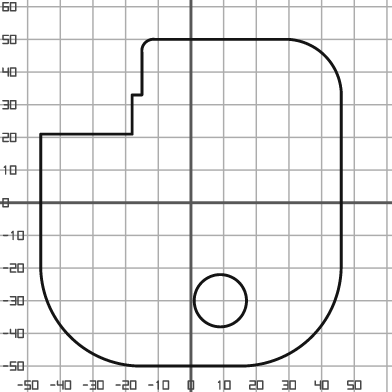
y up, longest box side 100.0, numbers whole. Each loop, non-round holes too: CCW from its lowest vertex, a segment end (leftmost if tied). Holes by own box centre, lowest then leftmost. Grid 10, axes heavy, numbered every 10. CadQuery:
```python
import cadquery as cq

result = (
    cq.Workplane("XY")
    .moveTo(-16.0, -50.0)
    .lineTo(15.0, -50.0)
    .threePointArc((37.0, -41.0), (46.0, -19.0))
    .lineTo(46.0, 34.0)
    .threePointArc((41.0, 45.0), (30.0, 50.0))
    .lineTo(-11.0, 50.0)
    .threePointArc((-14.0, 49.0), (-15.0, 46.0))
    .lineTo(-15.0, 33.0)
    .lineTo(-18.0, 33.0)
    .lineTo(-18.0, 21.0)
    .lineTo(-46.0, 21.0)
    .lineTo(-46.0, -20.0)
    .threePointArc((-37.0, -41.0), (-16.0, -50.0))
    .close()
    .moveTo(9.0, -30.0)
    .circle(8.0)
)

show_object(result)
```